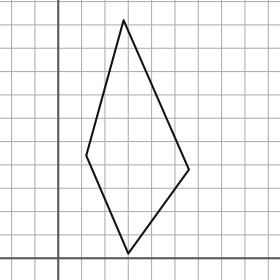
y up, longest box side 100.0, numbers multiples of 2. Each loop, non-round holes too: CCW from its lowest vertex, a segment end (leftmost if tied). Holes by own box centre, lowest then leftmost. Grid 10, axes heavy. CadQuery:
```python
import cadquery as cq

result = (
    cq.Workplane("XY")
    .moveTo(30.0, 2.0)
    .lineTo(56.0, 38.0)
    .lineTo(28.0, 102.0)
    .lineTo(12.0, 44.0)
    .close()
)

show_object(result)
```